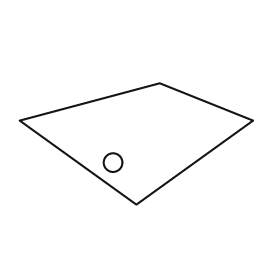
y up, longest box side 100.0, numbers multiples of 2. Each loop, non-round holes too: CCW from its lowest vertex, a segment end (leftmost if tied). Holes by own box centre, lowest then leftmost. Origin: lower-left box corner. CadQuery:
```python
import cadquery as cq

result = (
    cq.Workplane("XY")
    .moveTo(50.0, 0.0)
    .lineTo(100.0, 36.0)
    .lineTo(60.0, 52.0)
    .lineTo(0.0, 36.0)
    .close()
    .moveTo(40.0, 18.0)
    .circle(4.0)
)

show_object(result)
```